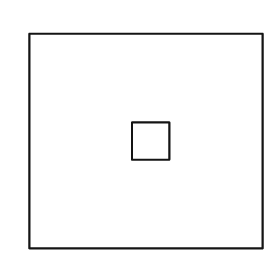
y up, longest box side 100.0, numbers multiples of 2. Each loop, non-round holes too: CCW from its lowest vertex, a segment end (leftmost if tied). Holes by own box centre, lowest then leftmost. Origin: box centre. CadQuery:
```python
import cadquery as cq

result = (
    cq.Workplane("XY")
    .moveTo(-50.0, -46.0)
    .lineTo(50.0, -46.0)
    .lineTo(50.0, 46.0)
    .lineTo(-50.0, 46.0)
    .close()
    .moveTo(-6.0, -8.0)
    .lineTo(10.0, -8.0)
    .lineTo(10.0, 8.0)
    .lineTo(-6.0, 8.0)
    .close()
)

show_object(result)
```